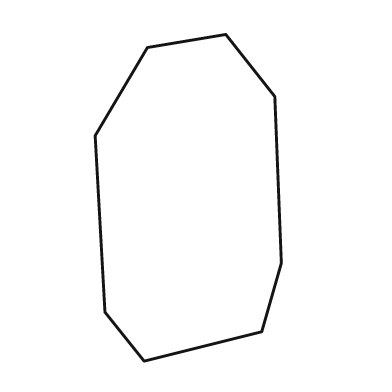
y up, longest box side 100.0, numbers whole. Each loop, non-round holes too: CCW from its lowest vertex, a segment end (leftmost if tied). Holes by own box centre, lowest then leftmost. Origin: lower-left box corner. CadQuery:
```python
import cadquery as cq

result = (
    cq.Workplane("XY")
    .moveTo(15.0, 0.0)
    .lineTo(51.0, 9.0)
    .lineTo(57.0, 30.0)
    .lineTo(55.0, 81.0)
    .lineTo(40.0, 100.0)
    .lineTo(16.0, 96.0)
    .lineTo(0.0, 69.0)
    .lineTo(3.0, 15.0)
    .close()
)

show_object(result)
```